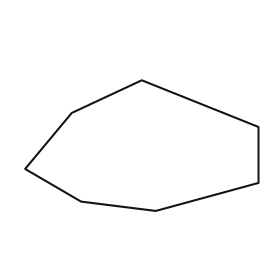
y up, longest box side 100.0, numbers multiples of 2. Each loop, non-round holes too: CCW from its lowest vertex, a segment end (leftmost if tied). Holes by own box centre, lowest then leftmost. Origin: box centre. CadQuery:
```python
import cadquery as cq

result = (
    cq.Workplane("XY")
    .moveTo(6.0, -28.0)
    .lineTo(50.0, -16.0)
    .lineTo(50.0, 8.0)
    .lineTo(0.0, 28.0)
    .lineTo(-30.0, 14.0)
    .lineTo(-50.0, -10.0)
    .lineTo(-26.0, -24.0)
    .close()
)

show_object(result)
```